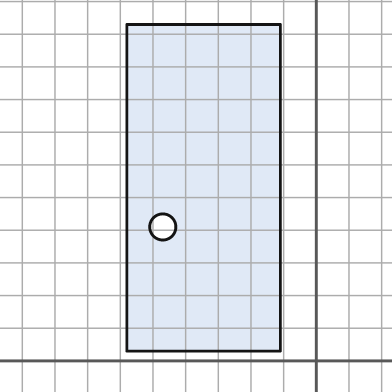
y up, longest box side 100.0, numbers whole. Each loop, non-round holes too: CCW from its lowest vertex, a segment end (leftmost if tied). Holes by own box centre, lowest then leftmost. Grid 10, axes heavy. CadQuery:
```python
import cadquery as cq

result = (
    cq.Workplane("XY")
    .moveTo(-58.0, 3.0)
    .lineTo(-11.0, 3.0)
    .lineTo(-11.0, 103.0)
    .lineTo(-58.0, 103.0)
    .close()
    .moveTo(-47.0, 41.0)
    .circle(4.0)
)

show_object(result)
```